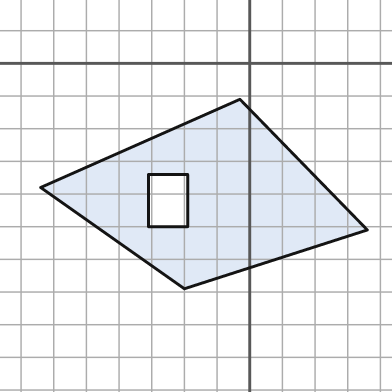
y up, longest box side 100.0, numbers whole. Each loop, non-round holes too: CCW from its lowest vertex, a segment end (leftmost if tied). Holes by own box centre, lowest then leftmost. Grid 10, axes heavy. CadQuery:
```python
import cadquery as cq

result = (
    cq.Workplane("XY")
    .moveTo(-20.0, -69.0)
    .lineTo(36.0, -51.0)
    .lineTo(-3.0, -11.0)
    .lineTo(-64.0, -38.0)
    .close()
    .moveTo(-31.0, -50.0)
    .lineTo(-19.0, -50.0)
    .lineTo(-19.0, -34.0)
    .lineTo(-31.0, -34.0)
    .close()
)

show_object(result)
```